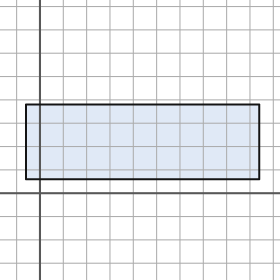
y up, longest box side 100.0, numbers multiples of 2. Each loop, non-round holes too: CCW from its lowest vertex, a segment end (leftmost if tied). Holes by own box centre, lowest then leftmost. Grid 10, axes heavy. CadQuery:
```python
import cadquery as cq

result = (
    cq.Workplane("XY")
    .moveTo(-6.0, 6.0)
    .lineTo(94.0, 6.0)
    .lineTo(94.0, 38.0)
    .lineTo(-6.0, 38.0)
    .close()
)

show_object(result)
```